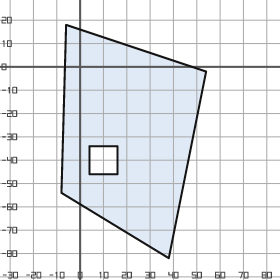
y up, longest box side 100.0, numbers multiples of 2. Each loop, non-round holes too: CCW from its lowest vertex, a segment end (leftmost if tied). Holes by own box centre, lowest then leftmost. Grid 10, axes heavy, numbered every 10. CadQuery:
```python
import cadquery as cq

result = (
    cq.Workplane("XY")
    .moveTo(38.0, -82.0)
    .lineTo(54.0, -2.0)
    .lineTo(-6.0, 18.0)
    .lineTo(-8.0, -54.0)
    .close()
    .moveTo(4.0, -46.0)
    .lineTo(16.0, -46.0)
    .lineTo(16.0, -34.0)
    .lineTo(4.0, -34.0)
    .close()
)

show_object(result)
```